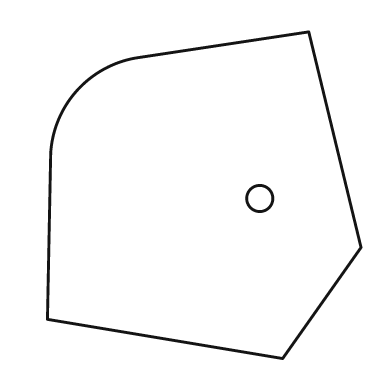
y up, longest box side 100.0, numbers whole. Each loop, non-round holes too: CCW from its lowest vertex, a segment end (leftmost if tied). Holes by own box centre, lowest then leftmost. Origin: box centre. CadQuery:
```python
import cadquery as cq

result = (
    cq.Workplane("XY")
    .moveTo(24.0, -50.0)
    .lineTo(48.0, -16.0)
    .lineTo(32.0, 50.0)
    .lineTo(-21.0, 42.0)
    .threePointArc((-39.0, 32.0), (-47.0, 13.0))
    .lineTo(-48.0, -38.0)
    .close()
    .moveTo(17.0, -1.0)
    .circle(4.0)
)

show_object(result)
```